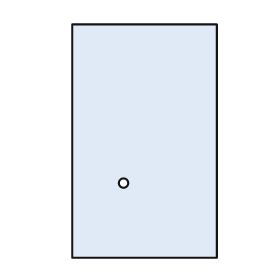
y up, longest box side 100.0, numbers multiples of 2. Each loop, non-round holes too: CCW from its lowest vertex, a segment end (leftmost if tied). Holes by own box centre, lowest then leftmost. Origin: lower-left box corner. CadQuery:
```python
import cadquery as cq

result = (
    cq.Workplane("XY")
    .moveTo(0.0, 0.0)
    .lineTo(62.0, 0.0)
    .lineTo(62.0, 100.0)
    .lineTo(0.0, 100.0)
    .close()
    .moveTo(22.0, 32.0)
    .circle(2.0)
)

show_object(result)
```